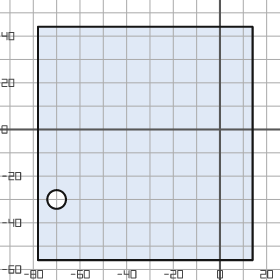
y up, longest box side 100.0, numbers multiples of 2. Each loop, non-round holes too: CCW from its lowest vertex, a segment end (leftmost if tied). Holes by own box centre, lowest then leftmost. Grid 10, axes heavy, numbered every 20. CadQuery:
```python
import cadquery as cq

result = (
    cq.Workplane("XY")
    .moveTo(-78.0, -56.0)
    .lineTo(14.0, -56.0)
    .lineTo(14.0, 44.0)
    .lineTo(-78.0, 44.0)
    .close()
    .moveTo(-70.0, -30.0)
    .circle(4.0)
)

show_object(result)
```